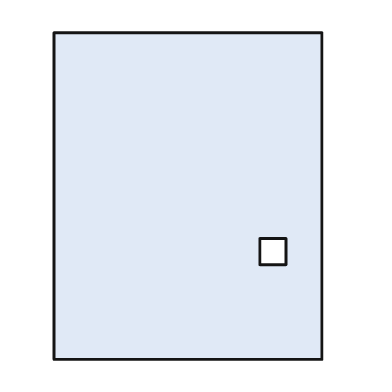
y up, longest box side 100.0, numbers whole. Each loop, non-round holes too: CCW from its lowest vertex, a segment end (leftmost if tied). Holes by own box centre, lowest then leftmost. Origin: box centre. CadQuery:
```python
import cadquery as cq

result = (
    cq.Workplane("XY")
    .moveTo(-41.0, -50.0)
    .lineTo(41.0, -50.0)
    .lineTo(41.0, 50.0)
    .lineTo(-41.0, 50.0)
    .close()
    .moveTo(22.0, -21.0)
    .lineTo(30.0, -21.0)
    .lineTo(30.0, -13.0)
    .lineTo(22.0, -13.0)
    .close()
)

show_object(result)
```